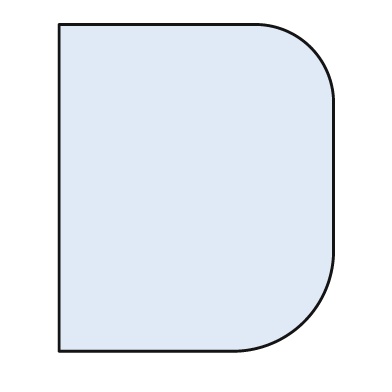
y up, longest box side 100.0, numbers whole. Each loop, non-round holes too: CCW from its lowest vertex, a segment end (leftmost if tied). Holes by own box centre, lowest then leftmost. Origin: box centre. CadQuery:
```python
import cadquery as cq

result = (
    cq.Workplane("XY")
    .moveTo(-42.0, -50.0)
    .lineTo(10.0, -50.0)
    .threePointArc((33.0, -41.0), (42.0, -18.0))
    .lineTo(42.0, 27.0)
    .threePointArc((35.0, 43.0), (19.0, 50.0))
    .lineTo(-42.0, 50.0)
    .close()
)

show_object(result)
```